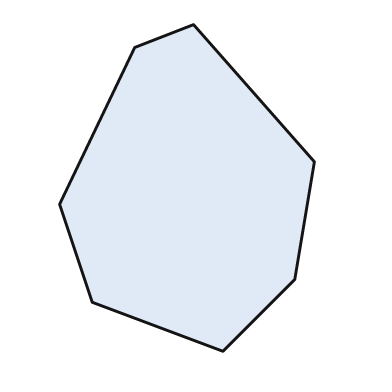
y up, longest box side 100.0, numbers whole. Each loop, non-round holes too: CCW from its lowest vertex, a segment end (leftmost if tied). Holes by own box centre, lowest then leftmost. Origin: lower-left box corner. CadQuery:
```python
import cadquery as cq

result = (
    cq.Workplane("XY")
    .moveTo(50.0, 0.0)
    .lineTo(72.0, 22.0)
    .lineTo(78.0, 58.0)
    .lineTo(41.0, 100.0)
    .lineTo(23.0, 93.0)
    .lineTo(0.0, 45.0)
    .lineTo(10.0, 15.0)
    .close()
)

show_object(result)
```